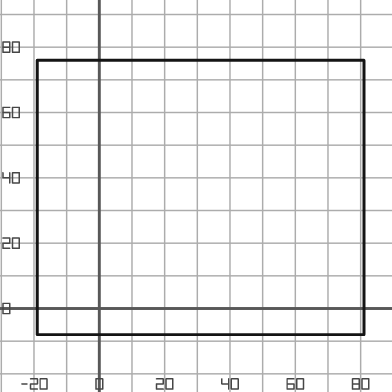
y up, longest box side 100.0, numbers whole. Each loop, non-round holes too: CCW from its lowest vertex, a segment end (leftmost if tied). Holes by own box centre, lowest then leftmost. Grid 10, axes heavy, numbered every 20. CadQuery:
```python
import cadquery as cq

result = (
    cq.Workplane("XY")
    .moveTo(-19.0, -8.0)
    .lineTo(81.0, -8.0)
    .lineTo(81.0, 76.0)
    .lineTo(-19.0, 76.0)
    .close()
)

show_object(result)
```